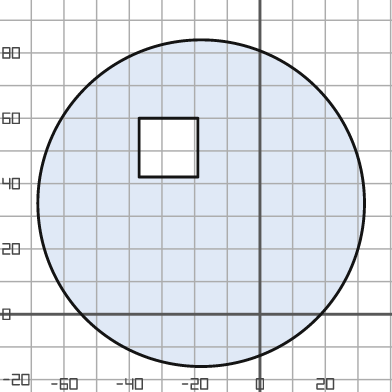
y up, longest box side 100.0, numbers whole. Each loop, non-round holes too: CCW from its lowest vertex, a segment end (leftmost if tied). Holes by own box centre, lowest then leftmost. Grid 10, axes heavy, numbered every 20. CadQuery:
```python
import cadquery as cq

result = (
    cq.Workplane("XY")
    .moveTo(-18.0, 34.0)
    .circle(50.0)
    .moveTo(-37.0, 42.0)
    .lineTo(-19.0, 42.0)
    .lineTo(-19.0, 60.0)
    .lineTo(-37.0, 60.0)
    .close()
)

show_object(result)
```